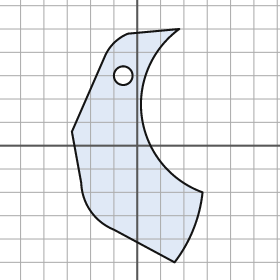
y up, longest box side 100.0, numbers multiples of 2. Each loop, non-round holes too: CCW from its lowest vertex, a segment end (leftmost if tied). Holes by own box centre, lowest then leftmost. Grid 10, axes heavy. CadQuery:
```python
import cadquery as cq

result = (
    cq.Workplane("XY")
    .moveTo(16.0, -50.0)
    .threePointArc((24.0, -36.0), (28.0, -20.0))
    .threePointArc((2.0, 12.0), (18.0, 50.0))
    .lineTo(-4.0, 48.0)
    .threePointArc((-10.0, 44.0), (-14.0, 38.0))
    .lineTo(-28.0, 6.0)
    .lineTo(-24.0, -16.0)
    .threePointArc((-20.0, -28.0), (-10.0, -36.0))
    .close()
    .moveTo(-6.0, 30.0)
    .circle(4.0)
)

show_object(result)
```